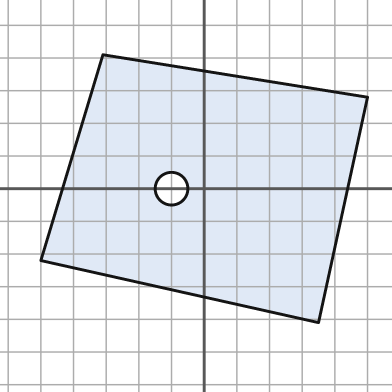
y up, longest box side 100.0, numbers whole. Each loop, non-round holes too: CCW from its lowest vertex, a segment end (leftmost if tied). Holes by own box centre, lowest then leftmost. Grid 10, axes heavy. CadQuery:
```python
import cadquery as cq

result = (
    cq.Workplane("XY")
    .moveTo(35.0, -41.0)
    .lineTo(50.0, 28.0)
    .lineTo(-31.0, 41.0)
    .lineTo(-50.0, -22.0)
    .close()
    .moveTo(-10.0, 0.0)
    .circle(5.0)
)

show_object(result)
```